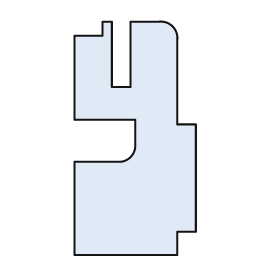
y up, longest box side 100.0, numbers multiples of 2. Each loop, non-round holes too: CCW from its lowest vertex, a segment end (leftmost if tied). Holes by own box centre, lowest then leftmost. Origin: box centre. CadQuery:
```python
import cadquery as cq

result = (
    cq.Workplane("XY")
    .moveTo(-26.0, -50.0)
    .lineTo(18.0, -50.0)
    .lineTo(18.0, -40.0)
    .lineTo(26.0, -40.0)
    .lineTo(26.0, 6.0)
    .lineTo(18.0, 6.0)
    .lineTo(18.0, 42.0)
    .threePointArc((16.0, 48.0), (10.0, 50.0))
    .lineTo(-2.0, 50.0)
    .lineTo(-2.0, 22.0)
    .lineTo(-10.0, 22.0)
    .lineTo(-10.0, 50.0)
    .lineTo(-14.0, 50.0)
    .lineTo(-14.0, 44.0)
    .lineTo(-26.0, 44.0)
    .lineTo(-26.0, 8.0)
    .lineTo(0.0, 8.0)
    .lineTo(0.0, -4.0)
    .threePointArc((-2.0, -8.0), (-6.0, -10.0))
    .lineTo(-26.0, -10.0)
    .close()
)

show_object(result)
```